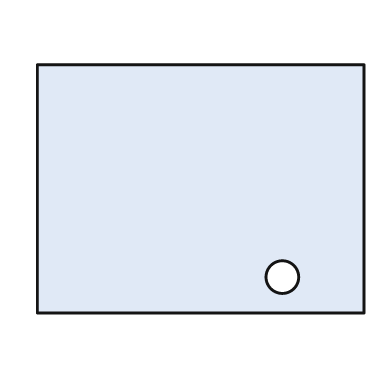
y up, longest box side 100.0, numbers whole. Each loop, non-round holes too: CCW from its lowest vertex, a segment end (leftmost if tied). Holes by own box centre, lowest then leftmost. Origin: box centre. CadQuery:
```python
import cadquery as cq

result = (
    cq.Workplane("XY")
    .moveTo(-50.0, -38.0)
    .lineTo(50.0, -38.0)
    .lineTo(50.0, 38.0)
    .lineTo(-50.0, 38.0)
    .close()
    .moveTo(25.0, -27.0)
    .circle(5.0)
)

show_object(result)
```